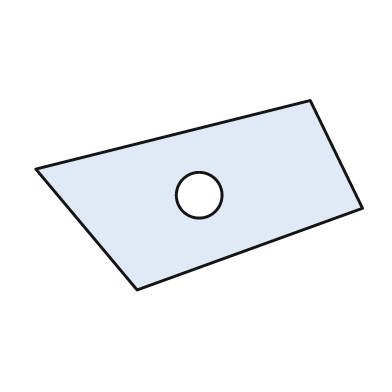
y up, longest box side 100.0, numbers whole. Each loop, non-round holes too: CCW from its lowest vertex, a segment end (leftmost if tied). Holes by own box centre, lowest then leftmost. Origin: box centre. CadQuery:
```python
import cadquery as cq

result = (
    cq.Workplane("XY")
    .moveTo(-19.0, -29.0)
    .lineTo(50.0, -4.0)
    .lineTo(34.0, 29.0)
    .lineTo(-50.0, 8.0)
    .close()
    .moveTo(0.0, 0.0)
    .circle(7.0)
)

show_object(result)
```